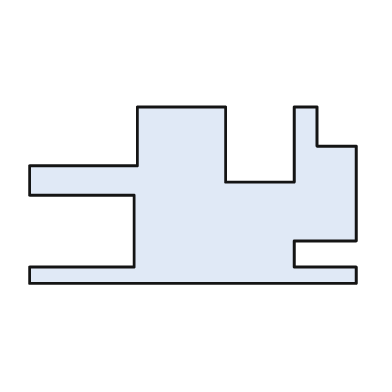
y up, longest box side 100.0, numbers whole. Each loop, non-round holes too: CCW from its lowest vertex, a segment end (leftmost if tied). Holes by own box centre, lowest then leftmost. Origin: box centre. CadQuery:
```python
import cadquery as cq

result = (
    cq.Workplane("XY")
    .moveTo(-50.0, -27.0)
    .lineTo(50.0, -27.0)
    .lineTo(50.0, -22.0)
    .lineTo(31.0, -22.0)
    .lineTo(31.0, -14.0)
    .lineTo(50.0, -14.0)
    .lineTo(50.0, 15.0)
    .lineTo(38.0, 15.0)
    .lineTo(38.0, 27.0)
    .lineTo(31.0, 27.0)
    .lineTo(31.0, 4.0)
    .lineTo(10.0, 4.0)
    .lineTo(10.0, 27.0)
    .lineTo(-17.0, 27.0)
    .lineTo(-17.0, 9.0)
    .lineTo(-50.0, 9.0)
    .lineTo(-50.0, 0.0)
    .lineTo(-18.0, 0.0)
    .lineTo(-18.0, -22.0)
    .lineTo(-50.0, -22.0)
    .close()
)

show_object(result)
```